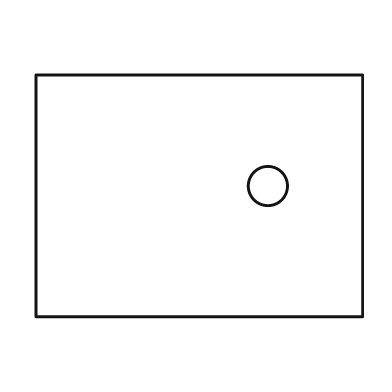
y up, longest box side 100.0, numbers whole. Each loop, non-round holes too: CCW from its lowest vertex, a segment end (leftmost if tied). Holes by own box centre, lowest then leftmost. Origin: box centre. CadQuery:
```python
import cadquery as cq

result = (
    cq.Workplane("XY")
    .moveTo(-50.0, -37.0)
    .lineTo(50.0, -37.0)
    .lineTo(50.0, 37.0)
    .lineTo(-50.0, 37.0)
    .close()
    .moveTo(21.0, 3.0)
    .circle(6.0)
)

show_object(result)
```